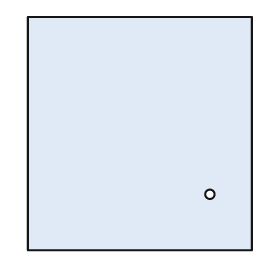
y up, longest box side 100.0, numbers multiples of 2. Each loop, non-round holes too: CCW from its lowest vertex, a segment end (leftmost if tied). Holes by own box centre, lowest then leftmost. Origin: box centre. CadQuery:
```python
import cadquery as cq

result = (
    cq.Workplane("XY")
    .moveTo(-48.0, -50.0)
    .lineTo(48.0, -50.0)
    .lineTo(48.0, 50.0)
    .lineTo(-48.0, 50.0)
    .close()
    .moveTo(30.0, -26.0)
    .circle(2.0)
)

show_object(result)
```